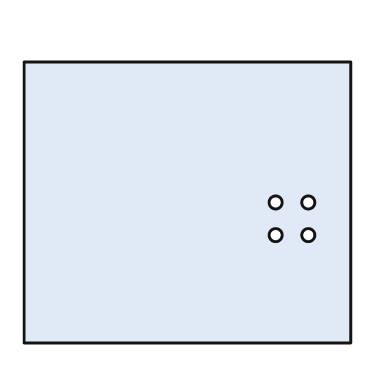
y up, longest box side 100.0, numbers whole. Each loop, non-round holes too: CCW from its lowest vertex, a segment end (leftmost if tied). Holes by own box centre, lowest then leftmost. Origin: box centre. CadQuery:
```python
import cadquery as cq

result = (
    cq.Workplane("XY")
    .moveTo(-50.0, -43.0)
    .lineTo(50.0, -43.0)
    .lineTo(50.0, 43.0)
    .lineTo(-50.0, 43.0)
    .close()
    .moveTo(27.0, -10.0)
    .circle(2.0)
    .moveTo(37.0, -10.0)
    .circle(2.0)
    .moveTo(27.0, 0.0)
    .circle(2.0)
    .moveTo(37.0, 0.0)
    .circle(2.0)
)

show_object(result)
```